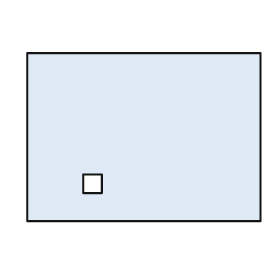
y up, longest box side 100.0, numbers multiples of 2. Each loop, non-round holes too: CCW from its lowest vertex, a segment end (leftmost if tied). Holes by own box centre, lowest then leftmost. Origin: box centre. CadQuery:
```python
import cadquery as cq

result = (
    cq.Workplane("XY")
    .moveTo(-50.0, -36.0)
    .lineTo(50.0, -36.0)
    .lineTo(50.0, 36.0)
    .lineTo(-50.0, 36.0)
    .close()
    .moveTo(-26.0, -24.0)
    .lineTo(-18.0, -24.0)
    .lineTo(-18.0, -16.0)
    .lineTo(-26.0, -16.0)
    .close()
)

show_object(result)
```